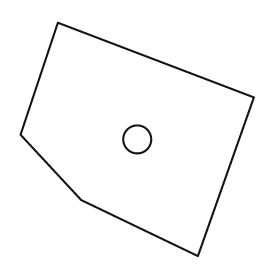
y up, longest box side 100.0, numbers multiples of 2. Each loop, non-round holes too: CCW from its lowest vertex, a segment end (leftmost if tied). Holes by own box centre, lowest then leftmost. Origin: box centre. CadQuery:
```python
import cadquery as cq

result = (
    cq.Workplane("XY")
    .moveTo(26.0, -50.0)
    .lineTo(50.0, 18.0)
    .lineTo(-34.0, 50.0)
    .lineTo(-50.0, 2.0)
    .lineTo(-24.0, -26.0)
    .close()
    .moveTo(0.0, 0.0)
    .circle(6.0)
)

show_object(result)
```